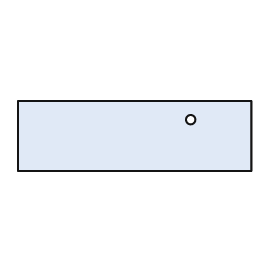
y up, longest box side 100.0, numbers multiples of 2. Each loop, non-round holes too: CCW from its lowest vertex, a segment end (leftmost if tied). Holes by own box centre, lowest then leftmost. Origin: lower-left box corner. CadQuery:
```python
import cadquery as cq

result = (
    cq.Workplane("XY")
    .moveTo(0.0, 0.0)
    .lineTo(100.0, 0.0)
    .lineTo(100.0, 30.0)
    .lineTo(0.0, 30.0)
    .close()
    .moveTo(74.0, 22.0)
    .circle(2.0)
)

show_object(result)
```